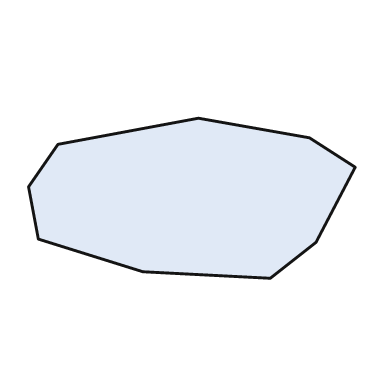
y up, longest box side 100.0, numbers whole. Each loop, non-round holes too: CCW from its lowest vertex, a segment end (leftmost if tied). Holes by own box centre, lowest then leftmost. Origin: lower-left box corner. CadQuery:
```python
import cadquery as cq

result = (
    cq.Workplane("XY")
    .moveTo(74.0, 0.0)
    .lineTo(88.0, 11.0)
    .lineTo(100.0, 34.0)
    .lineTo(86.0, 43.0)
    .lineTo(52.0, 49.0)
    .lineTo(9.0, 41.0)
    .lineTo(0.0, 28.0)
    .lineTo(3.0, 12.0)
    .lineTo(35.0, 2.0)
    .close()
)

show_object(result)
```